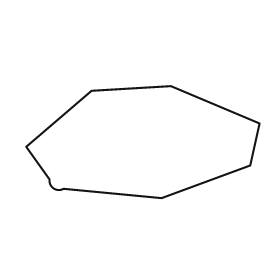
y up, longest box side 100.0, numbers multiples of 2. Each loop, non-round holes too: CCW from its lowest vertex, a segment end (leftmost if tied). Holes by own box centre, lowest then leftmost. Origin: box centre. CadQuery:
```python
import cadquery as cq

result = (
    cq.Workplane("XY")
    .moveTo(8.0, -24.0)
    .lineTo(46.0, -10.0)
    .lineTo(50.0, 8.0)
    .lineTo(12.0, 24.0)
    .lineTo(-22.0, 22.0)
    .lineTo(-50.0, -2.0)
    .lineTo(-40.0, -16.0)
    .threePointArc((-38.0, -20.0), (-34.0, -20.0))
    .close()
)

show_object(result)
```